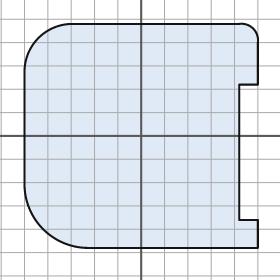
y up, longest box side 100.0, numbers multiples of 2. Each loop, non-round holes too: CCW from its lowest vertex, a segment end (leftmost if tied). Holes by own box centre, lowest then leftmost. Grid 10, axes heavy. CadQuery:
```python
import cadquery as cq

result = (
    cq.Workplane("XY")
    .moveTo(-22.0, -48.0)
    .lineTo(50.0, -48.0)
    .lineTo(50.0, -36.0)
    .lineTo(42.0, -36.0)
    .lineTo(42.0, 22.0)
    .lineTo(50.0, 22.0)
    .lineTo(50.0, 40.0)
    .threePointArc((48.0, 46.0), (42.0, 48.0))
    .lineTo(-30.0, 48.0)
    .threePointArc((-44.0, 42.0), (-50.0, 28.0))
    .lineTo(-50.0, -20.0)
    .threePointArc((-42.0, -40.0), (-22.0, -48.0))
    .close()
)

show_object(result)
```